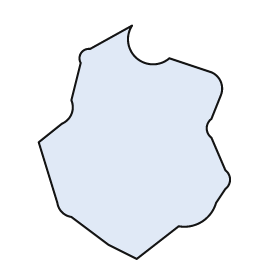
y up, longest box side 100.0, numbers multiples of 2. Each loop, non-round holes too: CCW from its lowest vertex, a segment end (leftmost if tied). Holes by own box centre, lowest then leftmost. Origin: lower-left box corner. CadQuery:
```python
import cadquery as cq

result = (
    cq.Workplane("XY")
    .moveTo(42.0, 0.0)
    .lineTo(60.0, 14.0)
    .threePointArc((70.0, 16.0), (76.0, 24.0))
    .lineTo(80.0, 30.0)
    .threePointArc((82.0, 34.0), (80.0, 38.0))
    .lineTo(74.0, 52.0)
    .threePointArc((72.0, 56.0), (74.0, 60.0))
    .lineTo(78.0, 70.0)
    .threePointArc((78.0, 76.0), (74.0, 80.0))
    .lineTo(56.0, 86.0)
    .threePointArc((42.0, 86.0), (40.0, 100.0))
    .lineTo(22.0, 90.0)
    .threePointArc((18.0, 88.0), (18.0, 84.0))
    .lineTo(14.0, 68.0)
    .threePointArc((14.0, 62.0), (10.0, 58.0))
    .lineTo(0.0, 50.0)
    .lineTo(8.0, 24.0)
    .threePointArc((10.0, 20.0), (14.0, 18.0))
    .lineTo(30.0, 6.0)
    .close()
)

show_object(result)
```